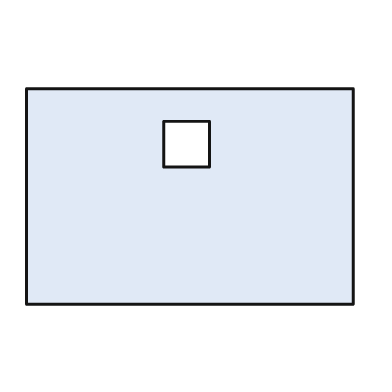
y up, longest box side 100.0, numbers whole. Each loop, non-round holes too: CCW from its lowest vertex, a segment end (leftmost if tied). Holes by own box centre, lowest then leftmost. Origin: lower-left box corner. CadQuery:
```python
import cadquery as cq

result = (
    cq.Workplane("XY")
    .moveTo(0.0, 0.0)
    .lineTo(100.0, 0.0)
    .lineTo(100.0, 66.0)
    .lineTo(0.0, 66.0)
    .close()
    .moveTo(42.0, 42.0)
    .lineTo(56.0, 42.0)
    .lineTo(56.0, 56.0)
    .lineTo(42.0, 56.0)
    .close()
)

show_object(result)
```